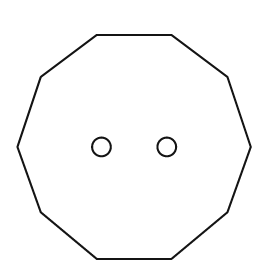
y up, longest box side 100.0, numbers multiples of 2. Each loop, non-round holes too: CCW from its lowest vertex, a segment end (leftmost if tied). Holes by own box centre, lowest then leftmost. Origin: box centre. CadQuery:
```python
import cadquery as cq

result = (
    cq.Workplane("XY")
    .moveTo(-16.0, -48.0)
    .lineTo(16.0, -48.0)
    .lineTo(40.0, -28.0)
    .lineTo(50.0, 0.0)
    .lineTo(40.0, 30.0)
    .lineTo(16.0, 48.0)
    .lineTo(-16.0, 48.0)
    .lineTo(-40.0, 30.0)
    .lineTo(-50.0, 0.0)
    .lineTo(-40.0, -28.0)
    .close()
    .moveTo(-14.0, 0.0)
    .circle(4.0)
    .moveTo(14.0, 0.0)
    .circle(4.0)
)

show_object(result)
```